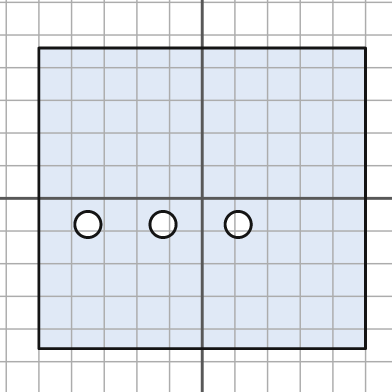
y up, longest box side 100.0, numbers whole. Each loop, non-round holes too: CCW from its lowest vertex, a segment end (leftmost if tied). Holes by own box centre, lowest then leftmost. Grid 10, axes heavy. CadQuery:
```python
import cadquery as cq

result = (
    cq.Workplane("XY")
    .moveTo(-50.0, -46.0)
    .lineTo(50.0, -46.0)
    .lineTo(50.0, 46.0)
    .lineTo(-50.0, 46.0)
    .close()
    .moveTo(-35.0, -8.0)
    .circle(4.0)
    .moveTo(-12.0, -8.0)
    .circle(4.0)
    .moveTo(11.0, -8.0)
    .circle(4.0)
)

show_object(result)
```